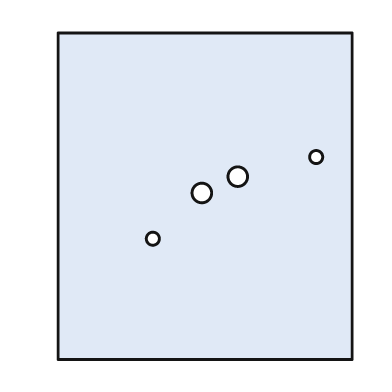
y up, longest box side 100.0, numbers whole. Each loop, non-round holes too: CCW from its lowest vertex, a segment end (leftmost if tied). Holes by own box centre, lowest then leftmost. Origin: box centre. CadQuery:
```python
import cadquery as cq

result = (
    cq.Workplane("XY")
    .moveTo(-45.0, -50.0)
    .lineTo(45.0, -50.0)
    .lineTo(45.0, 50.0)
    .lineTo(-45.0, 50.0)
    .close()
    .moveTo(-16.0, -13.0)
    .circle(2.0)
    .moveTo(-1.0, 1.0)
    .circle(3.0)
    .moveTo(10.0, 6.0)
    .circle(3.0)
    .moveTo(34.0, 12.0)
    .circle(2.0)
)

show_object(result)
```